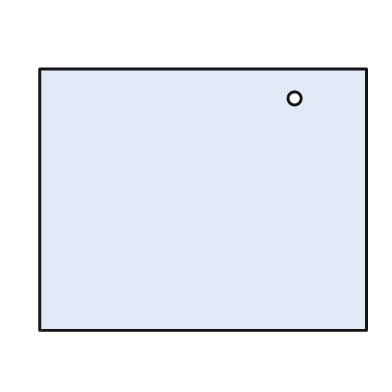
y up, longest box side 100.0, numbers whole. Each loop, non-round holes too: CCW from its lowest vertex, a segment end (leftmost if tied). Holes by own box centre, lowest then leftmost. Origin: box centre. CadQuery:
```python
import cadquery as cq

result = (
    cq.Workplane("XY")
    .moveTo(-50.0, -40.0)
    .lineTo(50.0, -40.0)
    .lineTo(50.0, 40.0)
    .lineTo(-50.0, 40.0)
    .close()
    .moveTo(28.0, 31.0)
    .circle(2.0)
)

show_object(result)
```